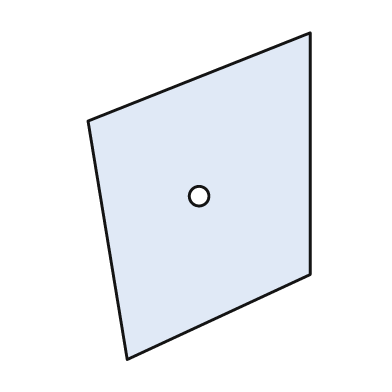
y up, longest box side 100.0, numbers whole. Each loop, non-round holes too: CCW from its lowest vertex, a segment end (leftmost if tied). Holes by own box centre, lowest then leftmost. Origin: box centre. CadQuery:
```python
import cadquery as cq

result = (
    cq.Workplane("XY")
    .moveTo(-22.0, -50.0)
    .lineTo(34.0, -24.0)
    .lineTo(34.0, 50.0)
    .lineTo(-34.0, 23.0)
    .close()
    .moveTo(0.0, 0.0)
    .circle(3.0)
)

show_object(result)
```